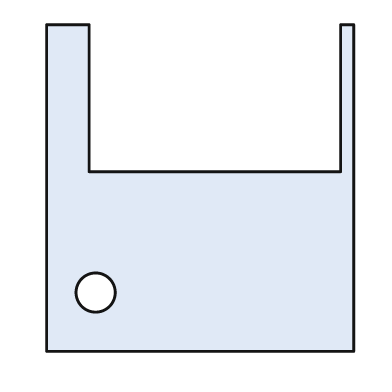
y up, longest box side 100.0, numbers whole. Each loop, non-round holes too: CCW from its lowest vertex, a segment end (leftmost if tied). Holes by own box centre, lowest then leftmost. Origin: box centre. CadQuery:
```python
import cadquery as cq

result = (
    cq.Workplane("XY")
    .moveTo(-47.0, -50.0)
    .lineTo(47.0, -50.0)
    .lineTo(47.0, 50.0)
    .lineTo(43.0, 50.0)
    .lineTo(43.0, 5.0)
    .lineTo(-34.0, 5.0)
    .lineTo(-34.0, 50.0)
    .lineTo(-47.0, 50.0)
    .close()
    .moveTo(-32.0, -32.0)
    .circle(6.0)
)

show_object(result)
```